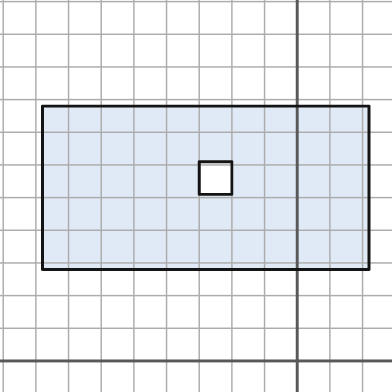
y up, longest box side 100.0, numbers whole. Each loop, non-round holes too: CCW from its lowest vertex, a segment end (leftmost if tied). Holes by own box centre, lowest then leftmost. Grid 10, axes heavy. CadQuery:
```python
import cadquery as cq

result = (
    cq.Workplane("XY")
    .moveTo(-78.0, 28.0)
    .lineTo(22.0, 28.0)
    .lineTo(22.0, 78.0)
    .lineTo(-78.0, 78.0)
    .close()
    .moveTo(-30.0, 51.0)
    .lineTo(-20.0, 51.0)
    .lineTo(-20.0, 61.0)
    .lineTo(-30.0, 61.0)
    .close()
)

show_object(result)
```